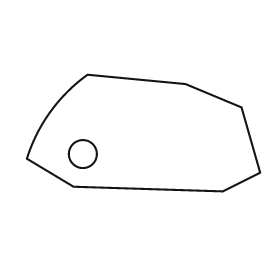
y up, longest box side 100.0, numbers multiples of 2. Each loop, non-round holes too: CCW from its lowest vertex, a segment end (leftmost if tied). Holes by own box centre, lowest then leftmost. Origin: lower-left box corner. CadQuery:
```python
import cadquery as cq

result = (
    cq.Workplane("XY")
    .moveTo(84.0, 0.0)
    .lineTo(100.0, 8.0)
    .lineTo(92.0, 36.0)
    .lineTo(68.0, 46.0)
    .lineTo(26.0, 50.0)
    .threePointArc((10.0, 34.0), (0.0, 14.0))
    .lineTo(20.0, 2.0)
    .close()
    .moveTo(24.0, 16.0)
    .circle(6.0)
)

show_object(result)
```